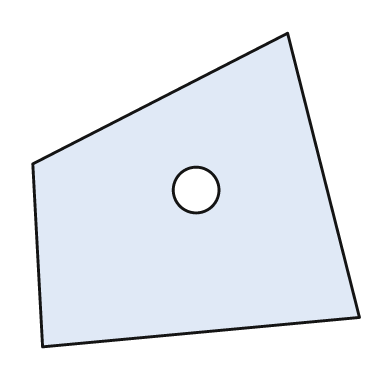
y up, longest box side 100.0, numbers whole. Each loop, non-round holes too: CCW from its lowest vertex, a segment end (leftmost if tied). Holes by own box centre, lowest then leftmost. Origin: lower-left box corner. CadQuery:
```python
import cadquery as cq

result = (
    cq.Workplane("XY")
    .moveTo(3.0, 0.0)
    .lineTo(100.0, 9.0)
    .lineTo(78.0, 96.0)
    .lineTo(0.0, 56.0)
    .close()
    .moveTo(50.0, 48.0)
    .circle(7.0)
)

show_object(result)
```